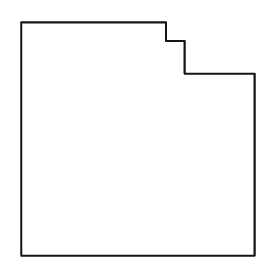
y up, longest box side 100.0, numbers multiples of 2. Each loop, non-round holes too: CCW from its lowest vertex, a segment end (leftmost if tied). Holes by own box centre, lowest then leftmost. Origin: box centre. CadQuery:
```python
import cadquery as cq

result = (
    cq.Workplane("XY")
    .moveTo(-50.0, -50.0)
    .lineTo(50.0, -50.0)
    .lineTo(50.0, 28.0)
    .lineTo(20.0, 28.0)
    .lineTo(20.0, 42.0)
    .lineTo(12.0, 42.0)
    .lineTo(12.0, 50.0)
    .lineTo(-50.0, 50.0)
    .close()
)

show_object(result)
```